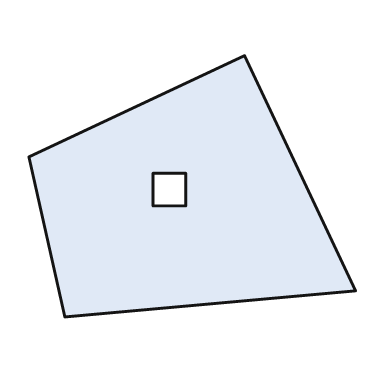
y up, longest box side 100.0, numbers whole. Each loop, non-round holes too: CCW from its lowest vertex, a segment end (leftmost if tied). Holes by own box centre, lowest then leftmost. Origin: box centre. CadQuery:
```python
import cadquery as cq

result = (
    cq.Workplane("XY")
    .moveTo(-39.0, -40.0)
    .lineTo(50.0, -32.0)
    .lineTo(16.0, 40.0)
    .lineTo(-50.0, 9.0)
    .close()
    .moveTo(-12.0, -6.0)
    .lineTo(-2.0, -6.0)
    .lineTo(-2.0, 4.0)
    .lineTo(-12.0, 4.0)
    .close()
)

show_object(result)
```